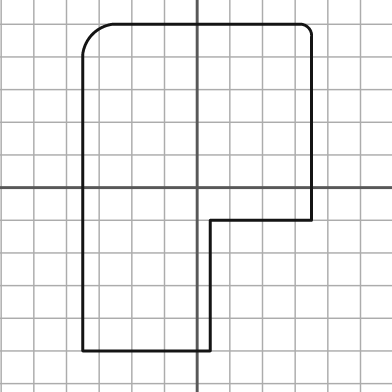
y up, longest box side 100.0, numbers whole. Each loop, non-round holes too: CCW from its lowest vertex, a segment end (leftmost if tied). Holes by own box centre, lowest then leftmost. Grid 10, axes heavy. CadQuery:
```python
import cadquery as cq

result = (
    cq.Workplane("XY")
    .moveTo(-35.0, -50.0)
    .lineTo(4.0, -50.0)
    .lineTo(4.0, -10.0)
    .lineTo(35.0, -10.0)
    .lineTo(35.0, 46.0)
    .threePointArc((34.0, 49.0), (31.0, 50.0))
    .lineTo(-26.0, 50.0)
    .threePointArc((-32.0, 47.0), (-35.0, 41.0))
    .close()
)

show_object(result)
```